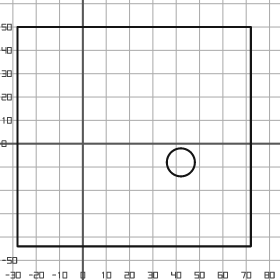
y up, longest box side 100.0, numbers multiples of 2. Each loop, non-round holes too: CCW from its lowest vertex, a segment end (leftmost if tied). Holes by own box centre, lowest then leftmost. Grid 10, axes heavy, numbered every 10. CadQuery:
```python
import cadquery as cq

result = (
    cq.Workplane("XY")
    .moveTo(-28.0, -44.0)
    .lineTo(72.0, -44.0)
    .lineTo(72.0, 50.0)
    .lineTo(-28.0, 50.0)
    .close()
    .moveTo(42.0, -8.0)
    .circle(6.0)
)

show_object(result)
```